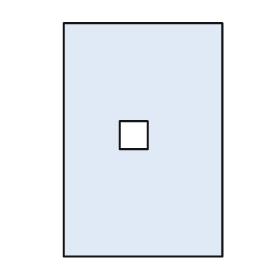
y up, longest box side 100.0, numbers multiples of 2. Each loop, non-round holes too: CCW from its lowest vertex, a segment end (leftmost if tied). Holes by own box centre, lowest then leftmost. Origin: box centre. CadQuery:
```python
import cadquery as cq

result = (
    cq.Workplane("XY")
    .moveTo(-34.0, -50.0)
    .lineTo(34.0, -50.0)
    .lineTo(34.0, 50.0)
    .lineTo(-34.0, 50.0)
    .close()
    .moveTo(-10.0, -4.0)
    .lineTo(2.0, -4.0)
    .lineTo(2.0, 8.0)
    .lineTo(-10.0, 8.0)
    .close()
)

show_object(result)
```